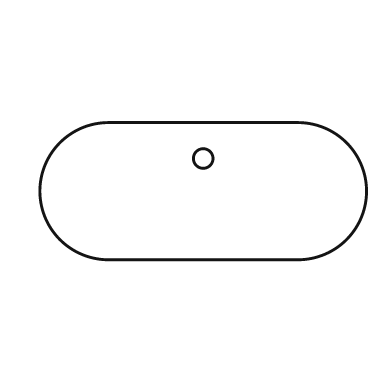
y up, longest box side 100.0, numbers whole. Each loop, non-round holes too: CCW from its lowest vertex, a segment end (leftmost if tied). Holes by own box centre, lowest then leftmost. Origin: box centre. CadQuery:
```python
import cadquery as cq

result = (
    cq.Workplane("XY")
    .moveTo(-29.0, -21.0)
    .lineTo(29.0, -21.0)
    .threePointArc((50.0, 0.0), (29.0, 21.0))
    .lineTo(-29.0, 21.0)
    .threePointArc((-50.0, 0.0), (-29.0, -21.0))
    .close()
    .moveTo(0.0, 10.0)
    .circle(3.0)
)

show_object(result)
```